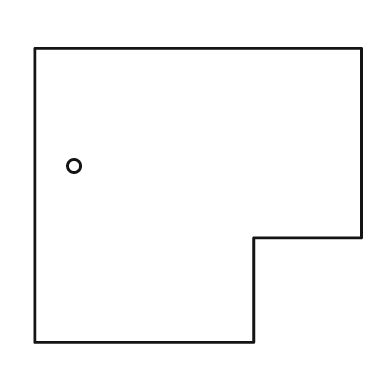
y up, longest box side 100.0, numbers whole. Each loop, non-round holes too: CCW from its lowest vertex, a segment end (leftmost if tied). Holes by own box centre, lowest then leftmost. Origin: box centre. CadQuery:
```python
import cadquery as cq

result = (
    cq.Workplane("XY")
    .moveTo(-50.0, -45.0)
    .lineTo(17.0, -45.0)
    .lineTo(17.0, -13.0)
    .lineTo(50.0, -13.0)
    .lineTo(50.0, 45.0)
    .lineTo(-50.0, 45.0)
    .close()
    .moveTo(-38.0, 9.0)
    .circle(2.0)
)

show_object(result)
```